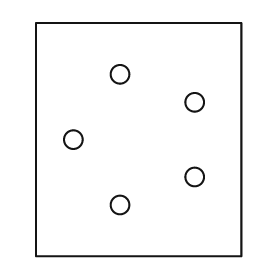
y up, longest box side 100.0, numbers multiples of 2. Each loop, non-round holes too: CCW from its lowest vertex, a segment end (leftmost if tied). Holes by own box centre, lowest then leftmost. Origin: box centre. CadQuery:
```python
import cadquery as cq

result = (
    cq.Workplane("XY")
    .moveTo(-44.0, -50.0)
    .lineTo(44.0, -50.0)
    .lineTo(44.0, 50.0)
    .lineTo(-44.0, 50.0)
    .close()
    .moveTo(-8.0, -28.0)
    .circle(4.0)
    .moveTo(24.0, -16.0)
    .circle(4.0)
    .moveTo(-28.0, 0.0)
    .circle(4.0)
    .moveTo(24.0, 16.0)
    .circle(4.0)
    .moveTo(-8.0, 28.0)
    .circle(4.0)
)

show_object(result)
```